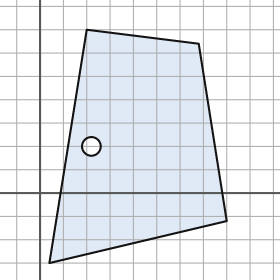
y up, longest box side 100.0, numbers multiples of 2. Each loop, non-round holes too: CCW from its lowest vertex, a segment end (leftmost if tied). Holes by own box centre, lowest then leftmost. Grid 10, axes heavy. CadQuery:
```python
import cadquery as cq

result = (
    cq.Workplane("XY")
    .moveTo(4.0, -30.0)
    .lineTo(80.0, -12.0)
    .lineTo(68.0, 64.0)
    .lineTo(20.0, 70.0)
    .close()
    .moveTo(22.0, 20.0)
    .circle(4.0)
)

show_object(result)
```